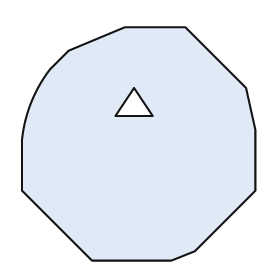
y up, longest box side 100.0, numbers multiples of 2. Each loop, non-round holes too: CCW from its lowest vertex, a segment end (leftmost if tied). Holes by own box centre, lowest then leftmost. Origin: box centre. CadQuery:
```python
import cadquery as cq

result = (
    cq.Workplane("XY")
    .moveTo(-20.0, -50.0)
    .lineTo(14.0, -50.0)
    .lineTo(24.0, -46.0)
    .lineTo(50.0, -20.0)
    .lineTo(50.0, 6.0)
    .lineTo(46.0, 24.0)
    .lineTo(20.0, 50.0)
    .lineTo(-6.0, 50.0)
    .lineTo(-30.0, 40.0)
    .lineTo(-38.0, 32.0)
    .threePointArc((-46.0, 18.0), (-50.0, 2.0))
    .lineTo(-50.0, -20.0)
    .close()
    .moveTo(-10.0, 12.0)
    .lineTo(6.0, 12.0)
    .lineTo(-2.0, 24.0)
    .close()
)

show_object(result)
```